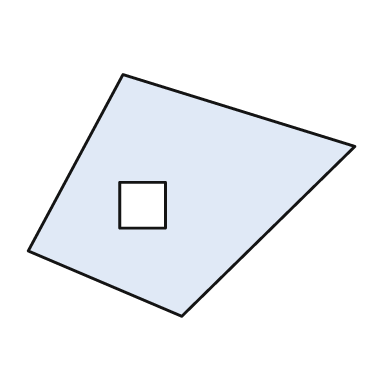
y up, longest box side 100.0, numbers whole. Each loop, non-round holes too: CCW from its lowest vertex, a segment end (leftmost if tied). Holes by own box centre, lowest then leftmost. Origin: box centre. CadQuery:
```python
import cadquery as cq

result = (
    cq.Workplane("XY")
    .moveTo(-3.0, -37.0)
    .lineTo(50.0, 15.0)
    .lineTo(-21.0, 37.0)
    .lineTo(-50.0, -17.0)
    .close()
    .moveTo(-22.0, -10.0)
    .lineTo(-8.0, -10.0)
    .lineTo(-8.0, 4.0)
    .lineTo(-22.0, 4.0)
    .close()
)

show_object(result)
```